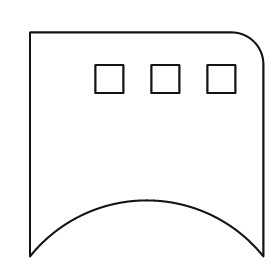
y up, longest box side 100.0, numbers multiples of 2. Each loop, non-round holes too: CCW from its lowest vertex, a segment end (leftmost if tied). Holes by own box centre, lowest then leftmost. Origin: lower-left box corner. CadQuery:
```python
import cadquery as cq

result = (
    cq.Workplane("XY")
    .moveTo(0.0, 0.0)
    .threePointArc((50.0, 24.0), (100.0, 0.0))
    .lineTo(100.0, 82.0)
    .threePointArc((96.0, 92.0), (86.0, 96.0))
    .lineTo(0.0, 96.0)
    .close()
    .moveTo(28.0, 70.0)
    .lineTo(40.0, 70.0)
    .lineTo(40.0, 82.0)
    .lineTo(28.0, 82.0)
    .close()
    .moveTo(52.0, 70.0)
    .lineTo(64.0, 70.0)
    .lineTo(64.0, 82.0)
    .lineTo(52.0, 82.0)
    .close()
    .moveTo(76.0, 70.0)
    .lineTo(88.0, 70.0)
    .lineTo(88.0, 82.0)
    .lineTo(76.0, 82.0)
    .close()
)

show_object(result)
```